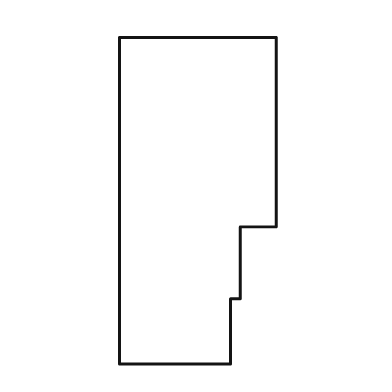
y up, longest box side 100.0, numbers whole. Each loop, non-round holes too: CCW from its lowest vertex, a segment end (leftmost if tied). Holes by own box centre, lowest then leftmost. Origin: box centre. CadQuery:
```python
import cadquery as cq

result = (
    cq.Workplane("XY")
    .moveTo(-24.0, -50.0)
    .lineTo(10.0, -50.0)
    .lineTo(10.0, -30.0)
    .lineTo(13.0, -30.0)
    .lineTo(13.0, -8.0)
    .lineTo(24.0, -8.0)
    .lineTo(24.0, 50.0)
    .lineTo(-24.0, 50.0)
    .close()
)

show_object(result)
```